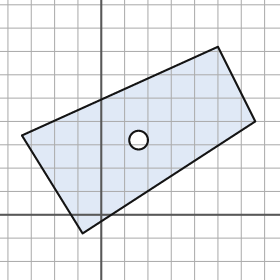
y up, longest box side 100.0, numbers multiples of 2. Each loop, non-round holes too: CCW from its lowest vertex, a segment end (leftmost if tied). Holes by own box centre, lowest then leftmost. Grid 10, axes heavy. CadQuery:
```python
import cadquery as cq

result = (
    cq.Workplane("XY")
    .moveTo(-8.0, -8.0)
    .lineTo(66.0, 40.0)
    .lineTo(50.0, 72.0)
    .lineTo(-34.0, 34.0)
    .close()
    .moveTo(16.0, 32.0)
    .circle(4.0)
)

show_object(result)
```